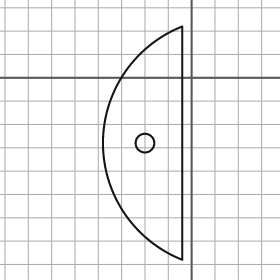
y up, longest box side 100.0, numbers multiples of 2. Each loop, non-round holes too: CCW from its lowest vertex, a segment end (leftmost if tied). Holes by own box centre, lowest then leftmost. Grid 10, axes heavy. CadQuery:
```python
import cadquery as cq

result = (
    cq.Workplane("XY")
    .moveTo(-4.0, -78.0)
    .lineTo(-4.0, 22.0)
    .threePointArc((-38.0, -28.0), (-4.0, -78.0))
    .close()
    .moveTo(-20.0, -28.0)
    .circle(4.0)
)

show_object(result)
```